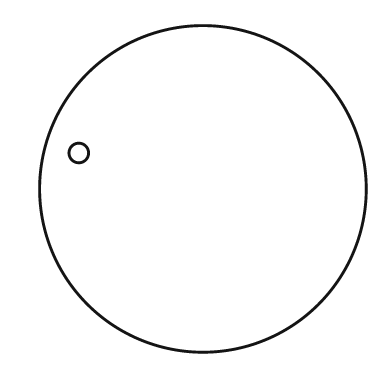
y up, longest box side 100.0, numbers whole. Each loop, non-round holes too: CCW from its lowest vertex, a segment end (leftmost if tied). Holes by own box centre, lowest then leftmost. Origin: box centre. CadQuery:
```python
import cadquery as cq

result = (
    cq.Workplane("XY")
    .moveTo(0.0, 0.0)
    .circle(50.0)
    .moveTo(-38.0, 11.0)
    .circle(3.0)
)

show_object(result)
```